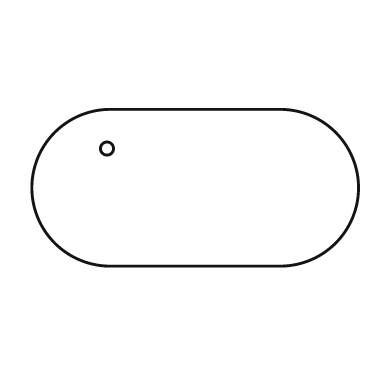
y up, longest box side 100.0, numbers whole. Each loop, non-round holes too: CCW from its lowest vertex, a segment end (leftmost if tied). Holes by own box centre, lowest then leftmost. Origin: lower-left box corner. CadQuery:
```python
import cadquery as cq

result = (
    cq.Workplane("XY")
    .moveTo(24.0, 0.0)
    .lineTo(76.0, 0.0)
    .threePointArc((100.0, 24.0), (76.0, 48.0))
    .lineTo(24.0, 48.0)
    .threePointArc((0.0, 24.0), (24.0, 0.0))
    .close()
    .moveTo(23.0, 36.0)
    .circle(2.0)
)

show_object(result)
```